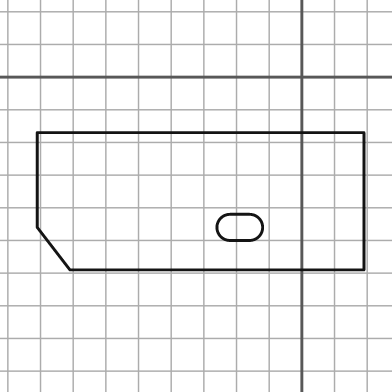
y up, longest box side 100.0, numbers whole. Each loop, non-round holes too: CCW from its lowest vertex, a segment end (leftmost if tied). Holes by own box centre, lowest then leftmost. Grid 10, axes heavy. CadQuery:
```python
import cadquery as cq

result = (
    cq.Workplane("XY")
    .moveTo(-71.0, -59.0)
    .lineTo(19.0, -59.0)
    .lineTo(19.0, -17.0)
    .lineTo(-81.0, -17.0)
    .lineTo(-81.0, -46.0)
    .close()
    .moveTo(-22.0, -50.0)
    .lineTo(-16.0, -50.0)
    .threePointArc((-12.0, -46.0), (-16.0, -42.0))
    .lineTo(-22.0, -42.0)
    .threePointArc((-26.0, -46.0), (-22.0, -50.0))
    .close()
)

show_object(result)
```